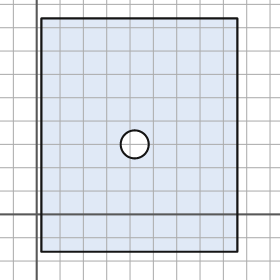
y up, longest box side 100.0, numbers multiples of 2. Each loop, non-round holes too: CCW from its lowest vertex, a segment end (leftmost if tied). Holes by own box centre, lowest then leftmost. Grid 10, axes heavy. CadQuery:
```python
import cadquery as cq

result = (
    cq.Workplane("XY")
    .moveTo(2.0, -16.0)
    .lineTo(86.0, -16.0)
    .lineTo(86.0, 84.0)
    .lineTo(2.0, 84.0)
    .close()
    .moveTo(42.0, 30.0)
    .circle(6.0)
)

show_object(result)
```